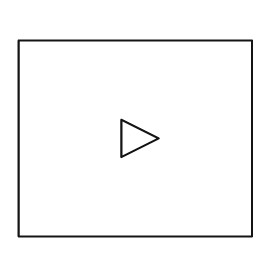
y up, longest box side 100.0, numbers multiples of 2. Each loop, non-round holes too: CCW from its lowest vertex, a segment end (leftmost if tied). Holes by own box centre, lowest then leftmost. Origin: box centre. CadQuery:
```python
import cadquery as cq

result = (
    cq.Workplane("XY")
    .moveTo(-50.0, -42.0)
    .lineTo(50.0, -42.0)
    .lineTo(50.0, 42.0)
    .lineTo(-50.0, 42.0)
    .close()
    .moveTo(-6.0, -8.0)
    .lineTo(10.0, 0.0)
    .lineTo(-6.0, 8.0)
    .close()
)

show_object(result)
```